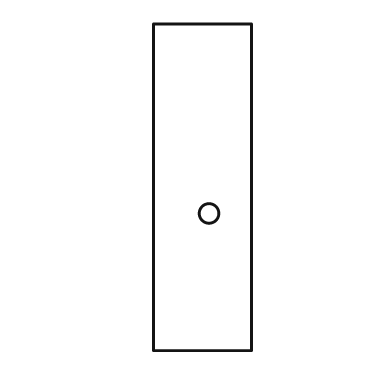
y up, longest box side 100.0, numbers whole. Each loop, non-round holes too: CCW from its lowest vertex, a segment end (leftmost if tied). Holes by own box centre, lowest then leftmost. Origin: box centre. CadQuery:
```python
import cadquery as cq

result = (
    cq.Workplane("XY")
    .moveTo(-15.0, -50.0)
    .lineTo(15.0, -50.0)
    .lineTo(15.0, 50.0)
    .lineTo(-15.0, 50.0)
    .close()
    .moveTo(2.0, -8.0)
    .circle(3.0)
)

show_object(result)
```